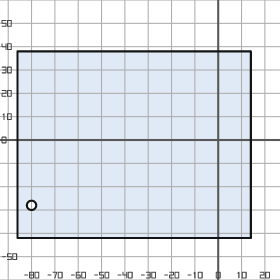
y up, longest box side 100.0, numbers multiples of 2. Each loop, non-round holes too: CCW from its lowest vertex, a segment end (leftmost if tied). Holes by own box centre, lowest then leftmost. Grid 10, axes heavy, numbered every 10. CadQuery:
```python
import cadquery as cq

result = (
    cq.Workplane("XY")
    .moveTo(-86.0, -42.0)
    .lineTo(14.0, -42.0)
    .lineTo(14.0, 38.0)
    .lineTo(-86.0, 38.0)
    .close()
    .moveTo(-80.0, -28.0)
    .circle(2.0)
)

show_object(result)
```